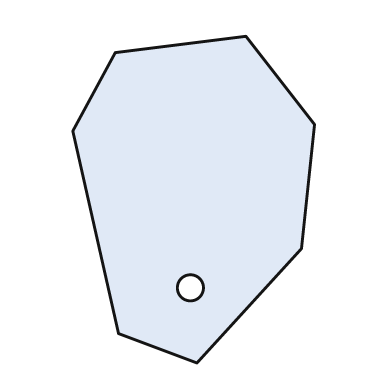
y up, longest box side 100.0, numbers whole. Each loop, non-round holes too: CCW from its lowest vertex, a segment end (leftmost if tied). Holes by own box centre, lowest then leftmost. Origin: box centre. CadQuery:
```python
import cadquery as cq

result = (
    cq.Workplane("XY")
    .moveTo(1.0, -50.0)
    .lineTo(33.0, -15.0)
    .lineTo(37.0, 23.0)
    .lineTo(16.0, 50.0)
    .lineTo(-24.0, 45.0)
    .lineTo(-37.0, 21.0)
    .lineTo(-23.0, -41.0)
    .close()
    .moveTo(-1.0, -27.0)
    .circle(4.0)
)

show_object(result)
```